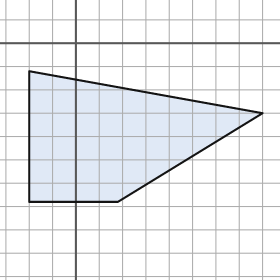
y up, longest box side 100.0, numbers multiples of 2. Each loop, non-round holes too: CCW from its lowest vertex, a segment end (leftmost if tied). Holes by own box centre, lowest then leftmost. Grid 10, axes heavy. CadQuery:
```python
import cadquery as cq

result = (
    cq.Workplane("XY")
    .moveTo(-20.0, -68.0)
    .lineTo(18.0, -68.0)
    .lineTo(80.0, -30.0)
    .lineTo(-20.0, -12.0)
    .close()
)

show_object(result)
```